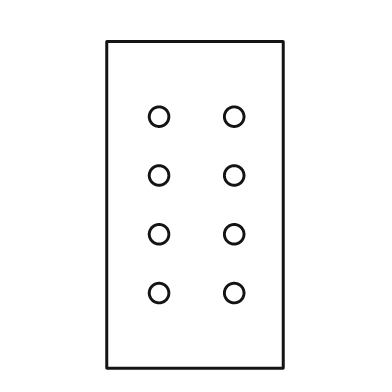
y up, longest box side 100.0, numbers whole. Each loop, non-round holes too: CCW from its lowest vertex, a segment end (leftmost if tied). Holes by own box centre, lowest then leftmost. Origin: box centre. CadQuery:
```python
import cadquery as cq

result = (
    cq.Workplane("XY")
    .moveTo(-27.0, -50.0)
    .lineTo(27.0, -50.0)
    .lineTo(27.0, 50.0)
    .lineTo(-27.0, 50.0)
    .close()
    .moveTo(-11.0, -27.0)
    .circle(3.0)
    .moveTo(12.0, -27.0)
    .circle(3.0)
    .moveTo(-11.0, -9.0)
    .circle(3.0)
    .moveTo(12.0, -9.0)
    .circle(3.0)
    .moveTo(-11.0, 9.0)
    .circle(3.0)
    .moveTo(12.0, 9.0)
    .circle(3.0)
    .moveTo(-11.0, 27.0)
    .circle(3.0)
    .moveTo(12.0, 27.0)
    .circle(3.0)
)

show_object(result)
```